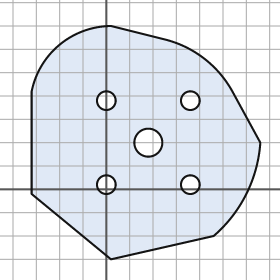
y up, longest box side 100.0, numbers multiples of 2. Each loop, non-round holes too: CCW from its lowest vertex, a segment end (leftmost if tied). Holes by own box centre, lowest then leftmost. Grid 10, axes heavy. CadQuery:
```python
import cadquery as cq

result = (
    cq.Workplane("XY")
    .moveTo(2.0, -30.0)
    .lineTo(46.0, -20.0)
    .threePointArc((60.0, -2.0), (66.0, 20.0))
    .lineTo(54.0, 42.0)
    .threePointArc((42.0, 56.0), (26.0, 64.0))
    .lineTo(2.0, 70.0)
    .threePointArc((-20.0, 62.0), (-32.0, 42.0))
    .lineTo(-32.0, -2.0)
    .close()
    .moveTo(0.0, 2.0)
    .circle(4.0)
    .moveTo(36.0, 2.0)
    .circle(4.0)
    .moveTo(18.0, 20.0)
    .circle(6.0)
    .moveTo(0.0, 38.0)
    .circle(4.0)
    .moveTo(36.0, 38.0)
    .circle(4.0)
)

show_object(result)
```